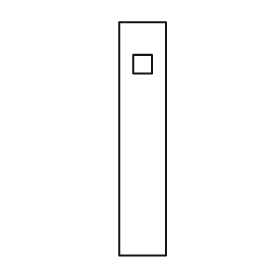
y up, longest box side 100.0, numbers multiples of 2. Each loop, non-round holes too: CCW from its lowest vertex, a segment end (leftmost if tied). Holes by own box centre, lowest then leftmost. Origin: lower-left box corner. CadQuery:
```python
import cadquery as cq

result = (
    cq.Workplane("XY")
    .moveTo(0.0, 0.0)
    .lineTo(20.0, 0.0)
    .lineTo(20.0, 100.0)
    .lineTo(0.0, 100.0)
    .close()
    .moveTo(6.0, 78.0)
    .lineTo(14.0, 78.0)
    .lineTo(14.0, 86.0)
    .lineTo(6.0, 86.0)
    .close()
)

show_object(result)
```